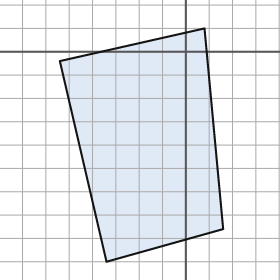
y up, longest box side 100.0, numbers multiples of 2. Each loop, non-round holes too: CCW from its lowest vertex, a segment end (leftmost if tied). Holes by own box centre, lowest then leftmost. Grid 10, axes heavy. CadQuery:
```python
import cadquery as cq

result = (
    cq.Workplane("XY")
    .moveTo(-34.0, -90.0)
    .lineTo(16.0, -76.0)
    .lineTo(8.0, 10.0)
    .lineTo(-54.0, -4.0)
    .close()
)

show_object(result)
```